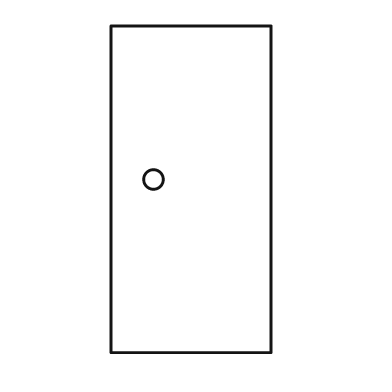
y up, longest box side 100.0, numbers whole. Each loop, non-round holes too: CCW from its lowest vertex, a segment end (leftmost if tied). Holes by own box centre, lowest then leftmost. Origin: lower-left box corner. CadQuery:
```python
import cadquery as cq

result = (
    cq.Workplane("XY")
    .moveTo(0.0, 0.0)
    .lineTo(49.0, 0.0)
    .lineTo(49.0, 100.0)
    .lineTo(0.0, 100.0)
    .close()
    .moveTo(13.0, 53.0)
    .circle(3.0)
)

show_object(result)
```